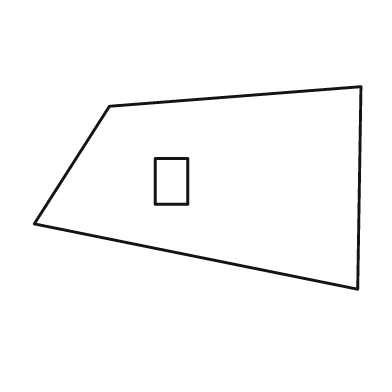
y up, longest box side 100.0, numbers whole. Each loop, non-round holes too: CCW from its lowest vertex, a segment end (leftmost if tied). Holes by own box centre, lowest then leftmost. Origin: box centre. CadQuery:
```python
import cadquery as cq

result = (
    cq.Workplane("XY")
    .moveTo(49.0, -31.0)
    .lineTo(50.0, 31.0)
    .lineTo(-27.0, 25.0)
    .lineTo(-50.0, -11.0)
    .close()
    .moveTo(-13.0, -5.0)
    .lineTo(-3.0, -5.0)
    .lineTo(-3.0, 9.0)
    .lineTo(-13.0, 9.0)
    .close()
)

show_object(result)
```